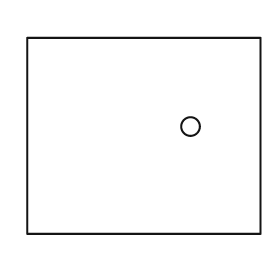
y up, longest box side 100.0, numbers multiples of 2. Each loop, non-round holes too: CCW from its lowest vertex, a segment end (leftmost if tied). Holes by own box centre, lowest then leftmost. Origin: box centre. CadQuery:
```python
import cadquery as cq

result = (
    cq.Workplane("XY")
    .moveTo(-50.0, -42.0)
    .lineTo(50.0, -42.0)
    .lineTo(50.0, 42.0)
    .lineTo(-50.0, 42.0)
    .close()
    .moveTo(20.0, 4.0)
    .circle(4.0)
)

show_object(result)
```